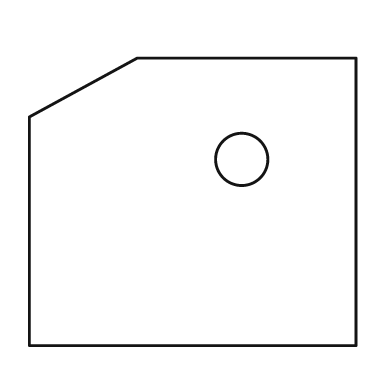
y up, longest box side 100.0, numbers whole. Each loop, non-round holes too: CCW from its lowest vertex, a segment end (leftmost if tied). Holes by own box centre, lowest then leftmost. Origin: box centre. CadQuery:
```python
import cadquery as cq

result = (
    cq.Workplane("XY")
    .moveTo(-50.0, -44.0)
    .lineTo(50.0, -44.0)
    .lineTo(50.0, 44.0)
    .lineTo(-17.0, 44.0)
    .lineTo(-50.0, 26.0)
    .close()
    .moveTo(15.0, 13.0)
    .circle(8.0)
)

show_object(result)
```